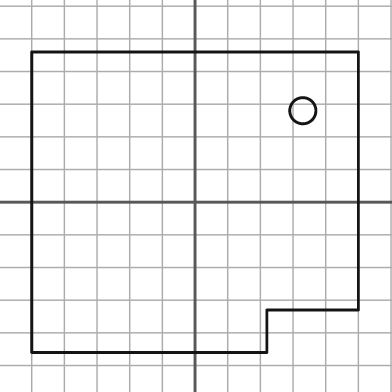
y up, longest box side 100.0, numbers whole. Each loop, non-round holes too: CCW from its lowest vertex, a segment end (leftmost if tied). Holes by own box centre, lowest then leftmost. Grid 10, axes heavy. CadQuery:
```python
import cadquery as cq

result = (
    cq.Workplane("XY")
    .moveTo(-50.0, -46.0)
    .lineTo(22.0, -46.0)
    .lineTo(22.0, -33.0)
    .lineTo(50.0, -33.0)
    .lineTo(50.0, 46.0)
    .lineTo(-50.0, 46.0)
    .close()
    .moveTo(33.0, 28.0)
    .circle(4.0)
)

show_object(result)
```